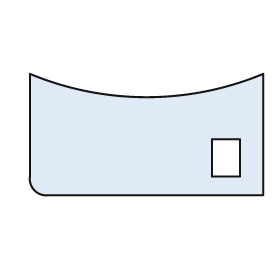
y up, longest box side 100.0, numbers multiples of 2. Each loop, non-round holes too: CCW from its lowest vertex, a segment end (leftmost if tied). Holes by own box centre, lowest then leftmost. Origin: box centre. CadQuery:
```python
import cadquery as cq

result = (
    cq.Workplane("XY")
    .moveTo(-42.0, -26.0)
    .lineTo(50.0, -26.0)
    .lineTo(50.0, 26.0)
    .threePointArc((0.0, 16.0), (-50.0, 26.0))
    .lineTo(-50.0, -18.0)
    .threePointArc((-48.0, -24.0), (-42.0, -26.0))
    .close()
    .moveTo(28.0, -18.0)
    .lineTo(40.0, -18.0)
    .lineTo(40.0, -2.0)
    .lineTo(28.0, -2.0)
    .close()
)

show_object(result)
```